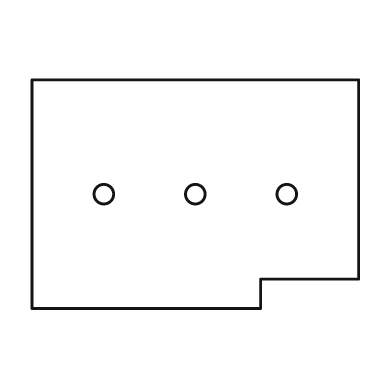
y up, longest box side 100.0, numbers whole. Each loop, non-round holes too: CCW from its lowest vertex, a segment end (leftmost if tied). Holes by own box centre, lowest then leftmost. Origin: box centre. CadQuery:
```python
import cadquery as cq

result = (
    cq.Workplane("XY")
    .moveTo(-50.0, -35.0)
    .lineTo(20.0, -35.0)
    .lineTo(20.0, -26.0)
    .lineTo(50.0, -26.0)
    .lineTo(50.0, 35.0)
    .lineTo(-50.0, 35.0)
    .close()
    .moveTo(-28.0, 0.0)
    .circle(3.0)
    .moveTo(0.0, 0.0)
    .circle(3.0)
    .moveTo(28.0, 0.0)
    .circle(3.0)
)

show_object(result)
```